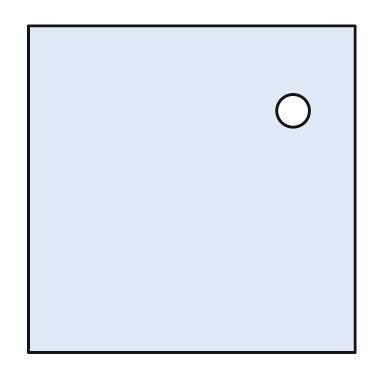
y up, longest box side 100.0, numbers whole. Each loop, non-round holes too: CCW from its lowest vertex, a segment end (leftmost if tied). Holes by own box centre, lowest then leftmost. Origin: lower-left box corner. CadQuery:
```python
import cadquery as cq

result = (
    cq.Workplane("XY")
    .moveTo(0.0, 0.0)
    .lineTo(100.0, 0.0)
    .lineTo(100.0, 100.0)
    .lineTo(0.0, 100.0)
    .close()
    .moveTo(81.0, 74.0)
    .circle(5.0)
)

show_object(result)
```